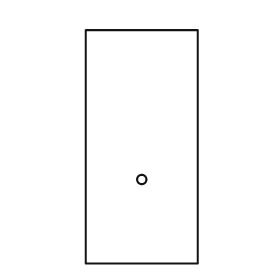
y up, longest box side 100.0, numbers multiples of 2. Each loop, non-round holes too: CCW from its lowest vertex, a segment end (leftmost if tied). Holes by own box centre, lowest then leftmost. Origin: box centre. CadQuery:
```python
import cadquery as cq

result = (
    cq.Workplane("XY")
    .moveTo(-24.0, -50.0)
    .lineTo(24.0, -50.0)
    .lineTo(24.0, 50.0)
    .lineTo(-24.0, 50.0)
    .close()
    .moveTo(0.0, -14.0)
    .circle(2.0)
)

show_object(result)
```